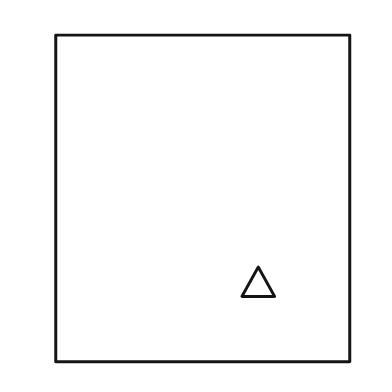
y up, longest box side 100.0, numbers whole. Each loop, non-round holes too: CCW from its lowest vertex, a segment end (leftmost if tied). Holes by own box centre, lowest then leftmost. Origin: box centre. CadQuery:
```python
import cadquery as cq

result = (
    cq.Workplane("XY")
    .moveTo(-45.0, -50.0)
    .lineTo(45.0, -50.0)
    .lineTo(45.0, 50.0)
    .lineTo(-45.0, 50.0)
    .close()
    .moveTo(12.0, -30.0)
    .lineTo(22.0, -30.0)
    .lineTo(17.0, -21.0)
    .close()
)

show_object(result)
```